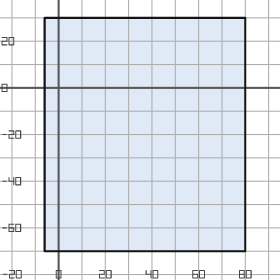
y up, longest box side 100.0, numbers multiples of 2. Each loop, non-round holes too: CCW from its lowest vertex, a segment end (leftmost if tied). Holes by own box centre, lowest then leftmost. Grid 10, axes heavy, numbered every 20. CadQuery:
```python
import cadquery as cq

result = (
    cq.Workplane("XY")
    .moveTo(-6.0, -70.0)
    .lineTo(80.0, -70.0)
    .lineTo(80.0, 30.0)
    .lineTo(-6.0, 30.0)
    .close()
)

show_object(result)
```